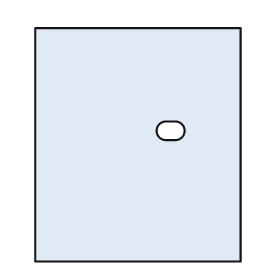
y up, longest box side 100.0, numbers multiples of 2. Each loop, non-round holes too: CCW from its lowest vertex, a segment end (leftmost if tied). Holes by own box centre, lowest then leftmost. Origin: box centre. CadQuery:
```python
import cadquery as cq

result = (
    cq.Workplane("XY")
    .moveTo(-44.0, -50.0)
    .lineTo(44.0, -50.0)
    .lineTo(44.0, 50.0)
    .lineTo(-44.0, 50.0)
    .close()
    .moveTo(12.0, 2.0)
    .lineTo(16.0, 2.0)
    .threePointArc((20.0, 6.0), (16.0, 10.0))
    .lineTo(12.0, 10.0)
    .threePointArc((8.0, 6.0), (12.0, 2.0))
    .close()
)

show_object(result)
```